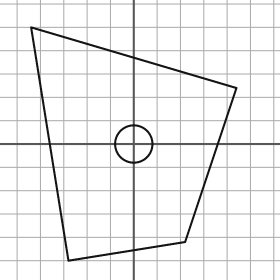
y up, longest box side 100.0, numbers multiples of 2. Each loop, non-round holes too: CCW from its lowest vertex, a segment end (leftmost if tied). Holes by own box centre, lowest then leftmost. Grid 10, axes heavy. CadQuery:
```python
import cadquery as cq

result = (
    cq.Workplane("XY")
    .moveTo(-28.0, -50.0)
    .lineTo(22.0, -42.0)
    .lineTo(44.0, 24.0)
    .lineTo(-44.0, 50.0)
    .close()
    .moveTo(0.0, 0.0)
    .circle(8.0)
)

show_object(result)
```